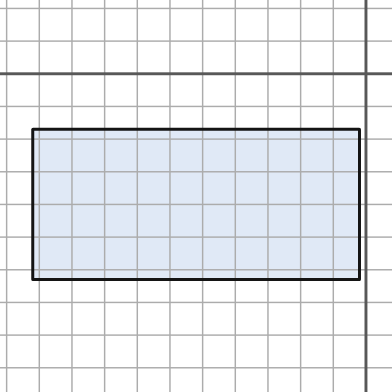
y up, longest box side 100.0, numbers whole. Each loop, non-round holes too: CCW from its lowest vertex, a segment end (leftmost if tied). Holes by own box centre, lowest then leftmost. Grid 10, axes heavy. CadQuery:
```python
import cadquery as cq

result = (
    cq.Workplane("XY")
    .moveTo(-102.0, -63.0)
    .lineTo(-2.0, -63.0)
    .lineTo(-2.0, -17.0)
    .lineTo(-102.0, -17.0)
    .close()
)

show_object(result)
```